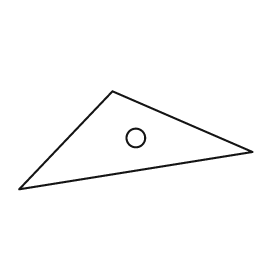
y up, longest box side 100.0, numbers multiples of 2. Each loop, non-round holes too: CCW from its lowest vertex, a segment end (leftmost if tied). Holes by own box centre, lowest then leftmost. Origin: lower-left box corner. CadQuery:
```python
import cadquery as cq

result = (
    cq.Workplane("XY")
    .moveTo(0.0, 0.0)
    .lineTo(100.0, 16.0)
    .lineTo(40.0, 42.0)
    .close()
    .moveTo(50.0, 22.0)
    .circle(4.0)
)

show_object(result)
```